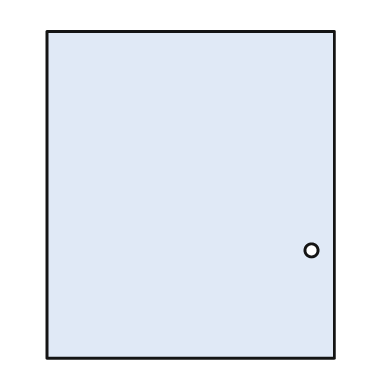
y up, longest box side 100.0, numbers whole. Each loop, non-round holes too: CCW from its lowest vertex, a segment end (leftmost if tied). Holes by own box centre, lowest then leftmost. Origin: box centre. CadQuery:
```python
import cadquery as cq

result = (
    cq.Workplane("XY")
    .moveTo(-44.0, -50.0)
    .lineTo(44.0, -50.0)
    .lineTo(44.0, 50.0)
    .lineTo(-44.0, 50.0)
    .close()
    .moveTo(37.0, -17.0)
    .circle(2.0)
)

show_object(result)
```